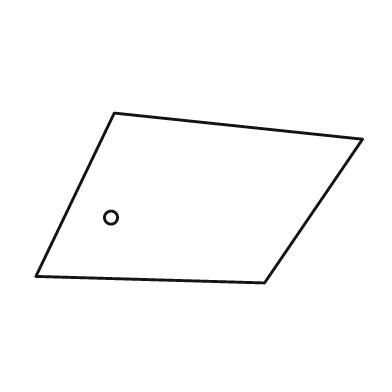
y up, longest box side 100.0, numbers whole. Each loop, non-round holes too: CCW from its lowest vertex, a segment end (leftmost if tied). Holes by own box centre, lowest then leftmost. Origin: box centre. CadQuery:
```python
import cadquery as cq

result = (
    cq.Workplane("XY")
    .moveTo(20.0, -26.0)
    .lineTo(50.0, 18.0)
    .lineTo(-26.0, 26.0)
    .lineTo(-50.0, -24.0)
    .close()
    .moveTo(-27.0, -6.0)
    .circle(2.0)
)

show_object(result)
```